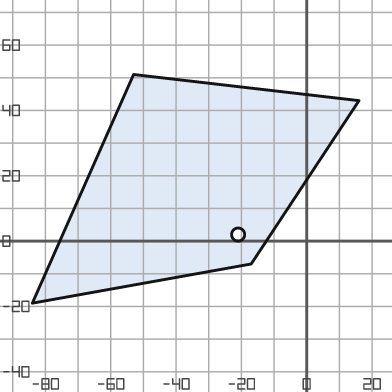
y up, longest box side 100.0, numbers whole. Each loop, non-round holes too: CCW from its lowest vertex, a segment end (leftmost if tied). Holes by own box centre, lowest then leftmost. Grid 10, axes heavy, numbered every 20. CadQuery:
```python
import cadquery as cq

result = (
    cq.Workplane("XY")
    .moveTo(-84.0, -19.0)
    .lineTo(-17.0, -7.0)
    .lineTo(16.0, 43.0)
    .lineTo(-53.0, 51.0)
    .close()
    .moveTo(-21.0, 2.0)
    .circle(2.0)
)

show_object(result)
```